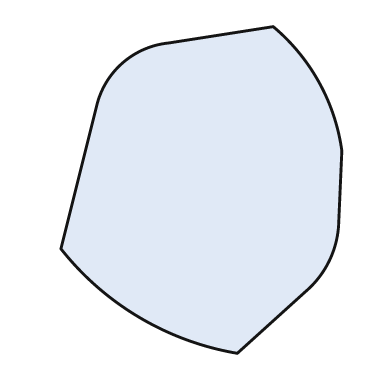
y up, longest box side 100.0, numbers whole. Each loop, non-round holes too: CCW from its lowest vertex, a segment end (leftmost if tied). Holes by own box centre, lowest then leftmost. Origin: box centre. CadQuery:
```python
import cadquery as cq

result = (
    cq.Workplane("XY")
    .moveTo(11.0, -50.0)
    .lineTo(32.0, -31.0)
    .threePointArc((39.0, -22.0), (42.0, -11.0))
    .lineTo(43.0, 12.0)
    .threePointArc((36.0, 33.0), (22.0, 50.0))
    .lineTo(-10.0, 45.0)
    .threePointArc((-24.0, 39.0), (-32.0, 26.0))
    .lineTo(-43.0, -18.0)
    .threePointArc((-19.0, -39.0), (11.0, -50.0))
    .close()
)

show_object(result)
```